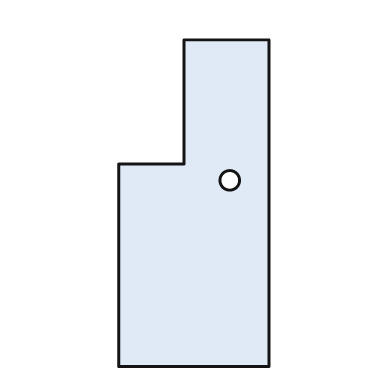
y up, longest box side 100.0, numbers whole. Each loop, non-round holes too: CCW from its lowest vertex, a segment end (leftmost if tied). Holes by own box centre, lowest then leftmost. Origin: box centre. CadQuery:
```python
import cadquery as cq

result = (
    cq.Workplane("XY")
    .moveTo(-23.0, -50.0)
    .lineTo(23.0, -50.0)
    .lineTo(23.0, 50.0)
    .lineTo(-3.0, 50.0)
    .lineTo(-3.0, 12.0)
    .lineTo(-23.0, 12.0)
    .close()
    .moveTo(11.0, 7.0)
    .circle(3.0)
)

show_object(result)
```